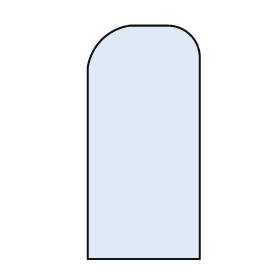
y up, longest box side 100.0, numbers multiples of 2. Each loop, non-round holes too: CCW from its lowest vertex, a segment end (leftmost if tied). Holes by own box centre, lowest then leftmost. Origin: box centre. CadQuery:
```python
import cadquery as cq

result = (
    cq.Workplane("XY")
    .moveTo(-24.0, -50.0)
    .lineTo(24.0, -50.0)
    .lineTo(24.0, 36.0)
    .threePointArc((20.0, 46.0), (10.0, 50.0))
    .lineTo(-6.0, 50.0)
    .threePointArc((-18.0, 44.0), (-24.0, 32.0))
    .close()
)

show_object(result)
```